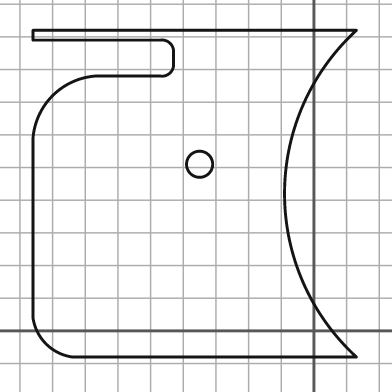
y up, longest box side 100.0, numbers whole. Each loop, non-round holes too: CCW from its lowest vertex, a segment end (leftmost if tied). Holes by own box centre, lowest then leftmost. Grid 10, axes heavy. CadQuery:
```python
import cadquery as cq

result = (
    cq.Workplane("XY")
    .moveTo(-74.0, -8.0)
    .lineTo(13.0, -8.0)
    .threePointArc((-9.0, 42.0), (13.0, 92.0))
    .lineTo(-86.0, 92.0)
    .lineTo(-86.0, 89.0)
    .lineTo(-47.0, 89.0)
    .threePointArc((-44.0, 88.0), (-43.0, 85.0))
    .lineTo(-43.0, 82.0)
    .threePointArc((-44.0, 79.0), (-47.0, 78.0))
    .lineTo(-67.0, 78.0)
    .threePointArc((-80.0, 72.0), (-86.0, 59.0))
    .lineTo(-86.0, 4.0)
    .threePointArc((-82.0, -4.0), (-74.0, -8.0))
    .close()
    .moveTo(-35.0, 51.0)
    .circle(4.0)
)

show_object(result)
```